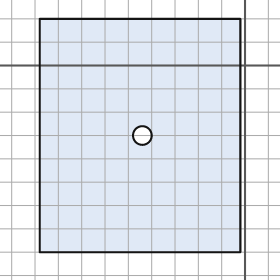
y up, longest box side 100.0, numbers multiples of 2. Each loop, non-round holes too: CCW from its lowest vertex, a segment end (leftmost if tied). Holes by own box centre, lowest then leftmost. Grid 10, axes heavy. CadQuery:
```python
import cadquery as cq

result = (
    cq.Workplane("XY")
    .moveTo(-88.0, -80.0)
    .lineTo(-2.0, -80.0)
    .lineTo(-2.0, 20.0)
    .lineTo(-88.0, 20.0)
    .close()
    .moveTo(-44.0, -30.0)
    .circle(4.0)
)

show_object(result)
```